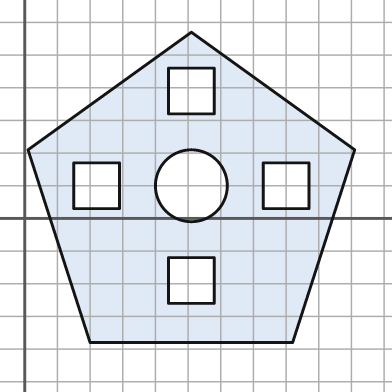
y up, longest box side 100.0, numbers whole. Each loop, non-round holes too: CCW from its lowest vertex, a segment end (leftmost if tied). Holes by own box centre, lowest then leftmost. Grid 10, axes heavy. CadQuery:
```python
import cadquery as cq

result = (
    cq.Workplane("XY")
    .moveTo(20.0, -38.0)
    .lineTo(82.0, -38.0)
    .lineTo(101.0, 21.0)
    .lineTo(51.0, 57.0)
    .lineTo(1.0, 21.0)
    .close()
    .moveTo(44.0, -26.0)
    .lineTo(58.0, -26.0)
    .lineTo(58.0, -12.0)
    .lineTo(44.0, -12.0)
    .close()
    .moveTo(15.0, 3.0)
    .lineTo(29.0, 3.0)
    .lineTo(29.0, 17.0)
    .lineTo(15.0, 17.0)
    .close()
    .moveTo(51.0, 10.0)
    .circle(11.0)
    .moveTo(73.0, 3.0)
    .lineTo(87.0, 3.0)
    .lineTo(87.0, 17.0)
    .lineTo(73.0, 17.0)
    .close()
    .moveTo(44.0, 32.0)
    .lineTo(58.0, 32.0)
    .lineTo(58.0, 46.0)
    .lineTo(44.0, 46.0)
    .close()
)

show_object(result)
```